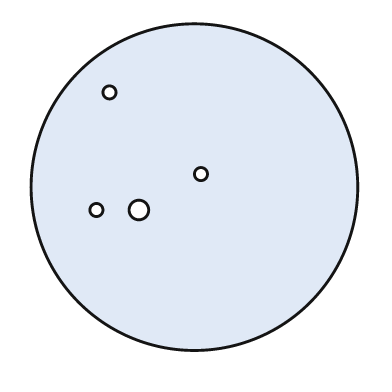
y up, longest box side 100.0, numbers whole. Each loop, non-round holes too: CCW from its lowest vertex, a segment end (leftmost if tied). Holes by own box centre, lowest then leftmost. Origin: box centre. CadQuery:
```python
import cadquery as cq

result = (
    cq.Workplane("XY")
    .moveTo(0.0, 0.0)
    .circle(50.0)
    .moveTo(-30.0, -7.0)
    .circle(2.0)
    .moveTo(-17.0, -7.0)
    .circle(3.0)
    .moveTo(2.0, 4.0)
    .circle(2.0)
    .moveTo(-26.0, 29.0)
    .circle(2.0)
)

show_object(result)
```